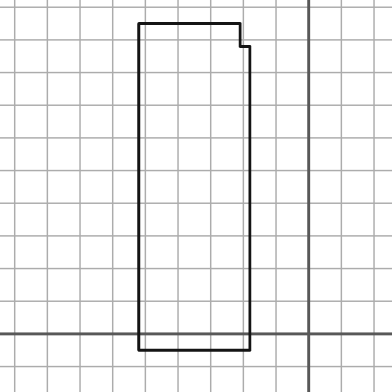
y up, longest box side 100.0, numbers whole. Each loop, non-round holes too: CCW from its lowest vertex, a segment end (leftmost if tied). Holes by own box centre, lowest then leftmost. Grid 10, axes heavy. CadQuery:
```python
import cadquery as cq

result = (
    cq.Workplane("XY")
    .moveTo(-52.0, -5.0)
    .lineTo(-18.0, -5.0)
    .lineTo(-18.0, 88.0)
    .lineTo(-21.0, 88.0)
    .lineTo(-21.0, 95.0)
    .lineTo(-52.0, 95.0)
    .close()
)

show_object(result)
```